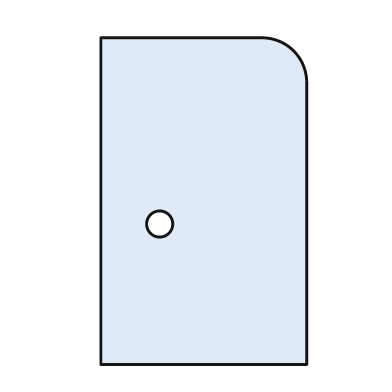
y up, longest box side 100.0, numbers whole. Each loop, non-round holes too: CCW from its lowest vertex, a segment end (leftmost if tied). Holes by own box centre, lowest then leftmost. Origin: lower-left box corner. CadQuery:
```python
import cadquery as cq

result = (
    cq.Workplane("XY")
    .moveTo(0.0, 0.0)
    .lineTo(63.0, 0.0)
    .lineTo(63.0, 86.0)
    .threePointArc((59.0, 96.0), (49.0, 100.0))
    .lineTo(0.0, 100.0)
    .close()
    .moveTo(18.0, 43.0)
    .circle(4.0)
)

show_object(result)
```